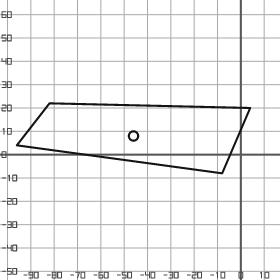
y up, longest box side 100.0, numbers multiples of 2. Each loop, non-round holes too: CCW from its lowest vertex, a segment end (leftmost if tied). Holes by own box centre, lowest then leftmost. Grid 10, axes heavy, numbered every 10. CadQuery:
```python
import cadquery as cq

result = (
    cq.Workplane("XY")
    .moveTo(-8.0, -8.0)
    .lineTo(4.0, 20.0)
    .lineTo(-82.0, 22.0)
    .lineTo(-96.0, 4.0)
    .close()
    .moveTo(-46.0, 8.0)
    .circle(2.0)
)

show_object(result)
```